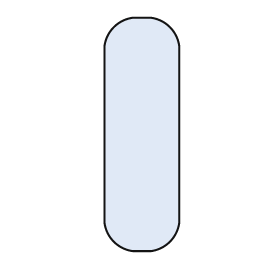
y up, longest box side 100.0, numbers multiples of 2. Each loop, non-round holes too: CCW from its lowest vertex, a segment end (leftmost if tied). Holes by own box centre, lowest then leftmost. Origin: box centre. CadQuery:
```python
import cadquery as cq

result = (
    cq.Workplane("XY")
    .moveTo(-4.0, -50.0)
    .lineTo(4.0, -50.0)
    .threePointArc((12.0, -46.0), (16.0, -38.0))
    .lineTo(16.0, 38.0)
    .threePointArc((12.0, 46.0), (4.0, 50.0))
    .lineTo(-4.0, 50.0)
    .threePointArc((-12.0, 46.0), (-16.0, 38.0))
    .lineTo(-16.0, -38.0)
    .threePointArc((-12.0, -46.0), (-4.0, -50.0))
    .close()
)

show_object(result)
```